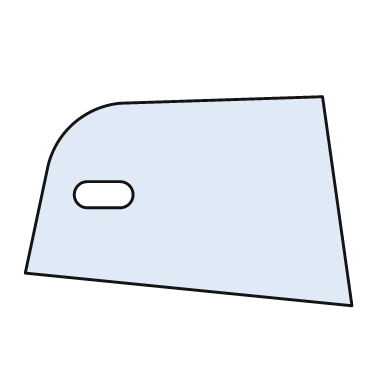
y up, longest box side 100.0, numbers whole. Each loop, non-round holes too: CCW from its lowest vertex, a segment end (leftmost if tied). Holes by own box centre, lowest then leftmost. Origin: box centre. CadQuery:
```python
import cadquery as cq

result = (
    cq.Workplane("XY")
    .moveTo(50.0, -32.0)
    .lineTo(41.0, 32.0)
    .lineTo(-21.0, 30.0)
    .threePointArc((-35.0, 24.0), (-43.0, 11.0))
    .lineTo(-50.0, -22.0)
    .close()
    .moveTo(-31.0, -2.0)
    .lineTo(-21.0, -2.0)
    .threePointArc((-17.0, 2.0), (-21.0, 6.0))
    .lineTo(-31.0, 6.0)
    .threePointArc((-35.0, 2.0), (-31.0, -2.0))
    .close()
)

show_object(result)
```